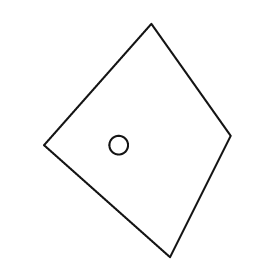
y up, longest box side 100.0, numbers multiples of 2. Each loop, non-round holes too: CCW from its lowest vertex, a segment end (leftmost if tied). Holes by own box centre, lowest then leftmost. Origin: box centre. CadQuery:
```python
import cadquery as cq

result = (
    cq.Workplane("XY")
    .moveTo(14.0, -50.0)
    .lineTo(40.0, 2.0)
    .lineTo(6.0, 50.0)
    .lineTo(-40.0, -2.0)
    .close()
    .moveTo(-8.0, -2.0)
    .circle(4.0)
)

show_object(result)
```